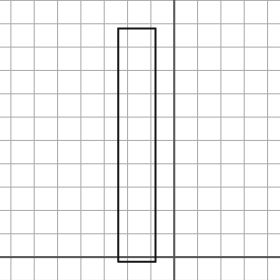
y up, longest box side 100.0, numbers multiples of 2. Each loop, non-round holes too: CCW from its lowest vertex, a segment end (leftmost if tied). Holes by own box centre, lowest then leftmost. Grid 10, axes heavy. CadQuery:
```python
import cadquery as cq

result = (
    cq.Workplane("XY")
    .moveTo(-24.0, -2.0)
    .lineTo(-8.0, -2.0)
    .lineTo(-8.0, 98.0)
    .lineTo(-24.0, 98.0)
    .close()
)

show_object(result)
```